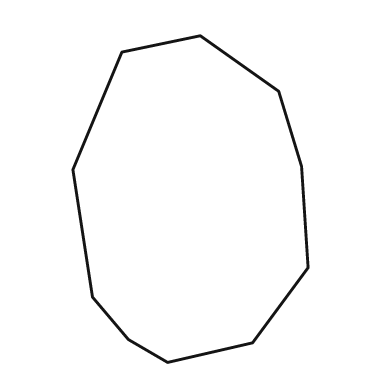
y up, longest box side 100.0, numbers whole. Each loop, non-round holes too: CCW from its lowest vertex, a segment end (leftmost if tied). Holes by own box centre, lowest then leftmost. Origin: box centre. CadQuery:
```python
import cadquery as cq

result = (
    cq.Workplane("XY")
    .moveTo(-7.0, -50.0)
    .lineTo(19.0, -44.0)
    .lineTo(36.0, -21.0)
    .lineTo(34.0, 10.0)
    .lineTo(27.0, 33.0)
    .lineTo(3.0, 50.0)
    .lineTo(-21.0, 45.0)
    .lineTo(-36.0, 9.0)
    .lineTo(-30.0, -30.0)
    .lineTo(-19.0, -43.0)
    .close()
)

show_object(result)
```